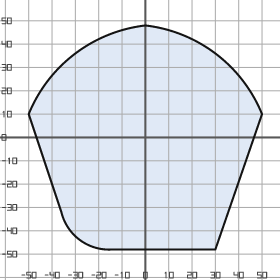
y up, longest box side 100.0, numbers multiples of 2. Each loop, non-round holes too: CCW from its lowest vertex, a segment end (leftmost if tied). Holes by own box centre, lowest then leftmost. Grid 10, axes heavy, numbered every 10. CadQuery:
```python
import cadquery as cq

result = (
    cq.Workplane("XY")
    .moveTo(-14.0, -48.0)
    .lineTo(30.0, -48.0)
    .lineTo(50.0, 10.0)
    .threePointArc((30.0, 36.0), (0.0, 48.0))
    .threePointArc((-30.0, 36.0), (-50.0, 10.0))
    .lineTo(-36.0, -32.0)
    .threePointArc((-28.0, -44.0), (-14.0, -48.0))
    .close()
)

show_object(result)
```